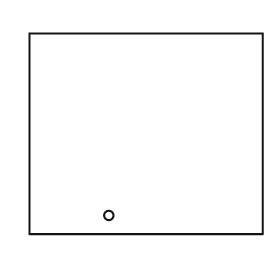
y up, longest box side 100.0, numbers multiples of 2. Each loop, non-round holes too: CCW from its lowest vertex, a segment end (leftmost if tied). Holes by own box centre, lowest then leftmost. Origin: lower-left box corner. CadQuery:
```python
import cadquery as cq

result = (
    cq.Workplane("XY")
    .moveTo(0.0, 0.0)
    .lineTo(100.0, 0.0)
    .lineTo(100.0, 86.0)
    .lineTo(0.0, 86.0)
    .close()
    .moveTo(34.0, 8.0)
    .circle(2.0)
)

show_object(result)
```